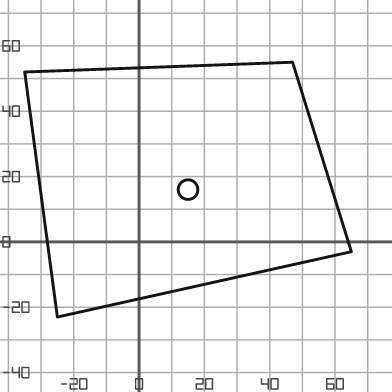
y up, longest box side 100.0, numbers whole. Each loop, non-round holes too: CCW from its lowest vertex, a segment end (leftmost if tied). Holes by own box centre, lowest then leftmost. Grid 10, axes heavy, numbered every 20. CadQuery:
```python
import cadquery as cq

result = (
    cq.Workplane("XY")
    .moveTo(-25.0, -23.0)
    .lineTo(65.0, -3.0)
    .lineTo(47.0, 55.0)
    .lineTo(-35.0, 52.0)
    .close()
    .moveTo(15.0, 16.0)
    .circle(3.0)
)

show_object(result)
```